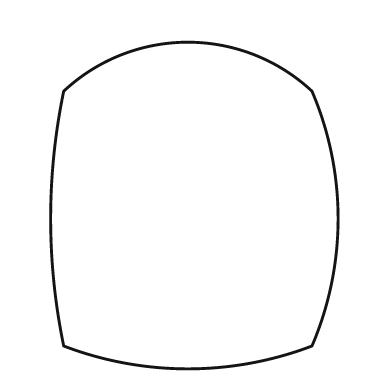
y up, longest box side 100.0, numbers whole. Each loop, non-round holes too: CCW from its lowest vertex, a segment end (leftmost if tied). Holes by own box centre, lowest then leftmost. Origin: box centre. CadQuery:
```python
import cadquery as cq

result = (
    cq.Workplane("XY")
    .moveTo(-40.0, -43.0)
    .threePointArc((-2.0, -50.0), (36.0, -43.0))
    .threePointArc((44.0, -4.0), (36.0, 35.0))
    .threePointArc((-2.0, 50.0), (-40.0, 35.0))
    .threePointArc((-44.0, -4.0), (-40.0, -43.0))
    .close()
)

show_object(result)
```